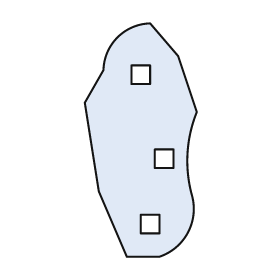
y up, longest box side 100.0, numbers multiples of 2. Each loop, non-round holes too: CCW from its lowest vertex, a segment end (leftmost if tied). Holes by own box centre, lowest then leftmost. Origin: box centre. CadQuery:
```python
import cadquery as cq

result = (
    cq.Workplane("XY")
    .moveTo(-6.0, -50.0)
    .lineTo(8.0, -50.0)
    .threePointArc((20.0, -40.0), (22.0, -24.0))
    .threePointArc((20.0, -6.0), (24.0, 12.0))
    .lineTo(16.0, 36.0)
    .lineTo(4.0, 50.0)
    .threePointArc((-10.0, 44.0), (-16.0, 30.0))
    .lineTo(-24.0, 16.0)
    .lineTo(-18.0, -22.0)
    .close()
    .moveTo(0.0, -40.0)
    .lineTo(8.0, -40.0)
    .lineTo(8.0, -32.0)
    .lineTo(0.0, -32.0)
    .close()
    .moveTo(6.0, -12.0)
    .lineTo(14.0, -12.0)
    .lineTo(14.0, -4.0)
    .lineTo(6.0, -4.0)
    .close()
    .moveTo(-4.0, 24.0)
    .lineTo(4.0, 24.0)
    .lineTo(4.0, 32.0)
    .lineTo(-4.0, 32.0)
    .close()
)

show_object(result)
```